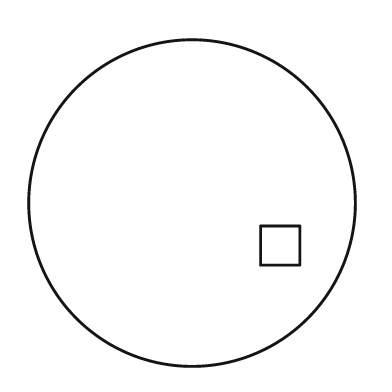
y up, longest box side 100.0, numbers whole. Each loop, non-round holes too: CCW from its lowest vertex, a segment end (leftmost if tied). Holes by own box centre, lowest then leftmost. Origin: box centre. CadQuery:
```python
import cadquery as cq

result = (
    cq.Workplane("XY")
    .moveTo(0.0, 0.0)
    .circle(50.0)
    .moveTo(21.0, -19.0)
    .lineTo(33.0, -19.0)
    .lineTo(33.0, -7.0)
    .lineTo(21.0, -7.0)
    .close()
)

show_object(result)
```